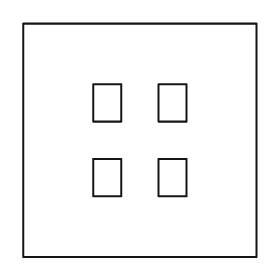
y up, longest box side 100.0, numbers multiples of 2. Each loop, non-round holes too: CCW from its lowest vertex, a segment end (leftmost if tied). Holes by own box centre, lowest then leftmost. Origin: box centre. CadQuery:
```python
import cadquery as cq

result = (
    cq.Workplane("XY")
    .moveTo(-50.0, -50.0)
    .lineTo(50.0, -50.0)
    .lineTo(50.0, 50.0)
    .lineTo(-50.0, 50.0)
    .close()
    .moveTo(-20.0, -24.0)
    .lineTo(-8.0, -24.0)
    .lineTo(-8.0, -8.0)
    .lineTo(-20.0, -8.0)
    .close()
    .moveTo(8.0, -24.0)
    .lineTo(20.0, -24.0)
    .lineTo(20.0, -8.0)
    .lineTo(8.0, -8.0)
    .close()
    .moveTo(-20.0, 8.0)
    .lineTo(-8.0, 8.0)
    .lineTo(-8.0, 24.0)
    .lineTo(-20.0, 24.0)
    .close()
    .moveTo(8.0, 8.0)
    .lineTo(20.0, 8.0)
    .lineTo(20.0, 24.0)
    .lineTo(8.0, 24.0)
    .close()
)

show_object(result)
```